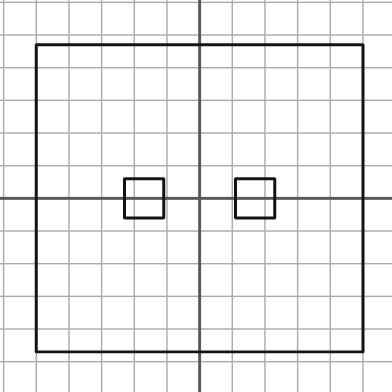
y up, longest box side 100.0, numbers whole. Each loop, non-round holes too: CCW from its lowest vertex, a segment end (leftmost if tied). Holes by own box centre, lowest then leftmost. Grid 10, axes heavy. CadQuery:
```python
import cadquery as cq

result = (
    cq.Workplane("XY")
    .moveTo(-50.0, -47.0)
    .lineTo(50.0, -47.0)
    .lineTo(50.0, 47.0)
    .lineTo(-50.0, 47.0)
    .close()
    .moveTo(-23.0, -6.0)
    .lineTo(-11.0, -6.0)
    .lineTo(-11.0, 6.0)
    .lineTo(-23.0, 6.0)
    .close()
    .moveTo(11.0, -6.0)
    .lineTo(23.0, -6.0)
    .lineTo(23.0, 6.0)
    .lineTo(11.0, 6.0)
    .close()
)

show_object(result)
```